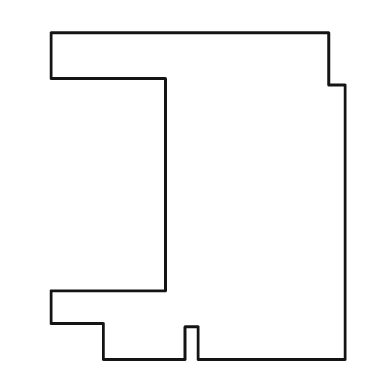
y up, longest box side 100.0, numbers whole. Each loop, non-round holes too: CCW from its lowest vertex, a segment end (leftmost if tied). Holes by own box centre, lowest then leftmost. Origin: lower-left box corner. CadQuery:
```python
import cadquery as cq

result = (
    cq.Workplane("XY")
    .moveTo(16.0, 0.0)
    .lineTo(41.0, 0.0)
    .lineTo(41.0, 10.0)
    .lineTo(45.0, 10.0)
    .lineTo(45.0, 0.0)
    .lineTo(90.0, 0.0)
    .lineTo(90.0, 84.0)
    .lineTo(85.0, 84.0)
    .lineTo(85.0, 100.0)
    .lineTo(0.0, 100.0)
    .lineTo(0.0, 86.0)
    .lineTo(35.0, 86.0)
    .lineTo(35.0, 21.0)
    .lineTo(0.0, 21.0)
    .lineTo(0.0, 11.0)
    .lineTo(16.0, 11.0)
    .close()
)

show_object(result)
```